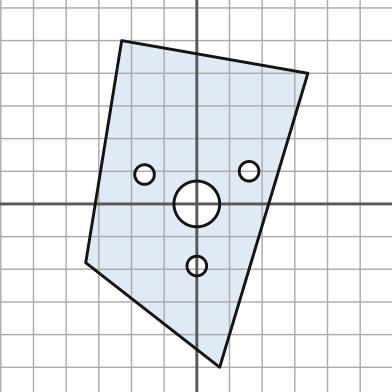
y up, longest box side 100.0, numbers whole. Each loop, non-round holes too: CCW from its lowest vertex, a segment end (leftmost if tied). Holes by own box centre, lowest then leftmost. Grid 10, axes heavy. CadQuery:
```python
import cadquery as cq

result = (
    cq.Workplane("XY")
    .moveTo(7.0, -50.0)
    .lineTo(34.0, 40.0)
    .lineTo(-23.0, 50.0)
    .lineTo(-34.0, -18.0)
    .close()
    .moveTo(0.0, -19.0)
    .circle(3.0)
    .moveTo(0.0, 0.0)
    .circle(7.0)
    .moveTo(-16.0, 9.0)
    .circle(3.0)
    .moveTo(16.0, 10.0)
    .circle(3.0)
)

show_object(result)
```